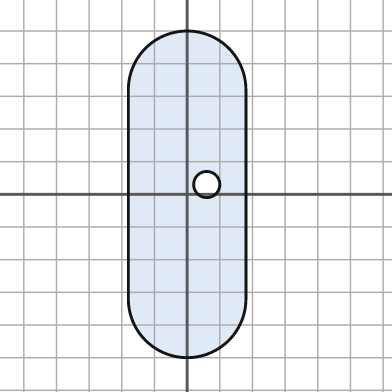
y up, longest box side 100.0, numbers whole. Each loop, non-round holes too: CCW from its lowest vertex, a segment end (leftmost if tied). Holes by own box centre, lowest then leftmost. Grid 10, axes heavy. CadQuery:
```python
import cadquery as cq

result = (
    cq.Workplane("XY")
    .moveTo(-18.0, -32.0)
    .threePointArc((0.0, -50.0), (18.0, -32.0))
    .lineTo(18.0, 32.0)
    .threePointArc((0.0, 50.0), (-18.0, 32.0))
    .close()
    .moveTo(6.0, 3.0)
    .circle(4.0)
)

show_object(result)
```